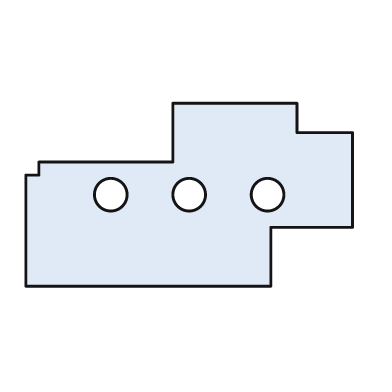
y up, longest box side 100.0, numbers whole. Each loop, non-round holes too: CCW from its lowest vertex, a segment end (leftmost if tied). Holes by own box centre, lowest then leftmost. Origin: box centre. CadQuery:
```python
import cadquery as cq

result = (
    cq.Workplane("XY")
    .moveTo(-50.0, -28.0)
    .lineTo(25.0, -28.0)
    .lineTo(25.0, -10.0)
    .lineTo(50.0, -10.0)
    .lineTo(50.0, 19.0)
    .lineTo(33.0, 19.0)
    .lineTo(33.0, 28.0)
    .lineTo(-5.0, 28.0)
    .lineTo(-5.0, 10.0)
    .lineTo(-46.0, 10.0)
    .lineTo(-46.0, 6.0)
    .lineTo(-50.0, 6.0)
    .close()
    .moveTo(-24.0, 0.0)
    .circle(5.0)
    .moveTo(0.0, 0.0)
    .circle(5.0)
    .moveTo(24.0, 0.0)
    .circle(5.0)
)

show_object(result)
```